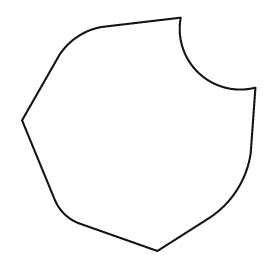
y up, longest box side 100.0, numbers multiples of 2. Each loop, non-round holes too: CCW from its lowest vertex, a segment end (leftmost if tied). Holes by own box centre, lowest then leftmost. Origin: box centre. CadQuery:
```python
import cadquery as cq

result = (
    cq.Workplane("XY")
    .moveTo(8.0, -50.0)
    .lineTo(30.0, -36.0)
    .threePointArc((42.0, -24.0), (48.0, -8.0))
    .lineTo(50.0, 20.0)
    .threePointArc((26.0, 26.0), (18.0, 50.0))
    .lineTo(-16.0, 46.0)
    .threePointArc((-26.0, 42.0), (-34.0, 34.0))
    .lineTo(-50.0, 6.0)
    .lineTo(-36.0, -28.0)
    .threePointArc((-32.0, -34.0), (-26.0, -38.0))
    .close()
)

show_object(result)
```